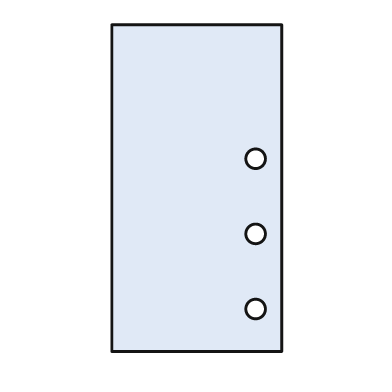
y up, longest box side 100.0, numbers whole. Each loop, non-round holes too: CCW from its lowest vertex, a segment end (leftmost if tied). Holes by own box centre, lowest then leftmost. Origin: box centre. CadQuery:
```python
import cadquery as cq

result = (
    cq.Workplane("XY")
    .moveTo(-26.0, -50.0)
    .lineTo(26.0, -50.0)
    .lineTo(26.0, 50.0)
    .lineTo(-26.0, 50.0)
    .close()
    .moveTo(18.0, -37.0)
    .circle(3.0)
    .moveTo(18.0, -14.0)
    .circle(3.0)
    .moveTo(18.0, 9.0)
    .circle(3.0)
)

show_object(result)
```